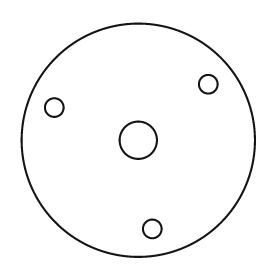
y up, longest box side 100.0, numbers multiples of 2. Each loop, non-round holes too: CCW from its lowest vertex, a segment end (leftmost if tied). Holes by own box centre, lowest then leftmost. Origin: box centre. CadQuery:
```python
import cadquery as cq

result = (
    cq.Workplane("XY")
    .moveTo(0.0, 0.0)
    .circle(50.0)
    .moveTo(6.0, -38.0)
    .circle(4.0)
    .moveTo(0.0, 0.0)
    .circle(8.0)
    .moveTo(-36.0, 14.0)
    .circle(4.0)
    .moveTo(30.0, 24.0)
    .circle(4.0)
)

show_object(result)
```